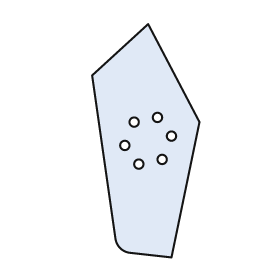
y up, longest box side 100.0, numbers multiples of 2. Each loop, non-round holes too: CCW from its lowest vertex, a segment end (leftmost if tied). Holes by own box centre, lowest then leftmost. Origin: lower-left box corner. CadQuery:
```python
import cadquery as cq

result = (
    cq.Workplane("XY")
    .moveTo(34.0, 0.0)
    .lineTo(46.0, 58.0)
    .lineTo(24.0, 100.0)
    .lineTo(0.0, 78.0)
    .lineTo(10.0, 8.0)
    .threePointArc((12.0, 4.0), (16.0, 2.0))
    .close()
    .moveTo(20.0, 40.0)
    .circle(2.0)
    .moveTo(30.0, 42.0)
    .circle(2.0)
    .moveTo(14.0, 48.0)
    .circle(2.0)
    .moveTo(34.0, 52.0)
    .circle(2.0)
    .moveTo(18.0, 58.0)
    .circle(2.0)
    .moveTo(28.0, 60.0)
    .circle(2.0)
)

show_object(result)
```